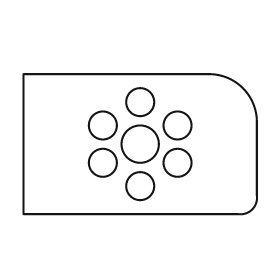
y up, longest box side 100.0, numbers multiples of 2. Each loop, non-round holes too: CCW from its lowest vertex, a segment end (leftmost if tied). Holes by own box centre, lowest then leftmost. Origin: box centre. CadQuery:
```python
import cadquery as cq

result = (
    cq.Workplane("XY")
    .moveTo(-50.0, -30.0)
    .lineTo(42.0, -30.0)
    .threePointArc((48.0, -28.0), (50.0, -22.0))
    .lineTo(50.0, 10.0)
    .threePointArc((44.0, 24.0), (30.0, 30.0))
    .lineTo(-50.0, 30.0)
    .close()
    .moveTo(0.0, -18.0)
    .circle(6.0)
    .moveTo(-16.0, -8.0)
    .circle(6.0)
    .moveTo(16.0, -8.0)
    .circle(6.0)
    .moveTo(0.0, 0.0)
    .circle(8.0)
    .moveTo(-16.0, 8.0)
    .circle(6.0)
    .moveTo(16.0, 8.0)
    .circle(6.0)
    .moveTo(0.0, 18.0)
    .circle(6.0)
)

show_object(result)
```